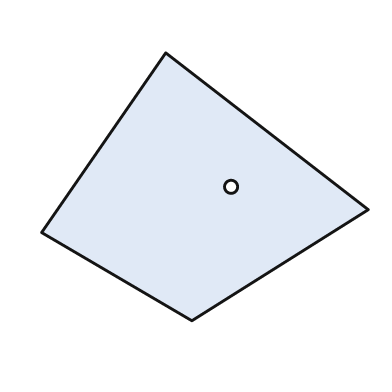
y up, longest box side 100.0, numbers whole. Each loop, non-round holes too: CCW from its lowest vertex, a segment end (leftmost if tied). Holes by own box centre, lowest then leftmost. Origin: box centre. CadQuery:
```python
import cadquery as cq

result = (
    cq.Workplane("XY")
    .moveTo(-4.0, -41.0)
    .lineTo(50.0, -7.0)
    .lineTo(-12.0, 41.0)
    .lineTo(-50.0, -14.0)
    .close()
    .moveTo(8.0, 0.0)
    .circle(2.0)
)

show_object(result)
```